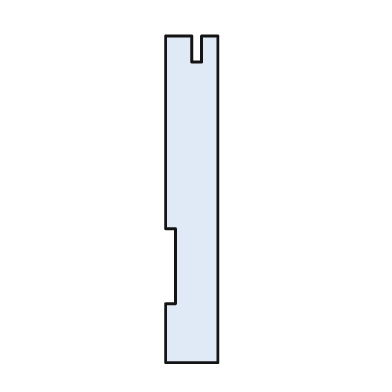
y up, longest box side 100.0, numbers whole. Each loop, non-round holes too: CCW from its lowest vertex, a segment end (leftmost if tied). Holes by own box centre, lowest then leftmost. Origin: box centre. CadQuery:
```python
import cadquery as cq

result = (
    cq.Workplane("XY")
    .moveTo(-8.0, -50.0)
    .lineTo(8.0, -50.0)
    .lineTo(8.0, 50.0)
    .lineTo(3.0, 50.0)
    .lineTo(3.0, 42.0)
    .lineTo(0.0, 42.0)
    .lineTo(0.0, 50.0)
    .lineTo(-8.0, 50.0)
    .lineTo(-8.0, -9.0)
    .lineTo(-5.0, -9.0)
    .lineTo(-5.0, -32.0)
    .lineTo(-8.0, -32.0)
    .close()
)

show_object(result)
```